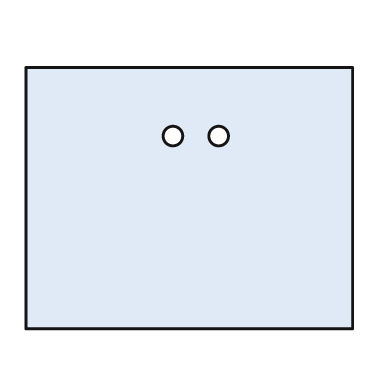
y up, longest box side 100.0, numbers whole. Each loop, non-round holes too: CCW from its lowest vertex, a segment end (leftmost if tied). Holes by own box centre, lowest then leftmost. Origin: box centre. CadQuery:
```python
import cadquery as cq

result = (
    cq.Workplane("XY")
    .moveTo(-50.0, -40.0)
    .lineTo(50.0, -40.0)
    .lineTo(50.0, 40.0)
    .lineTo(-50.0, 40.0)
    .close()
    .moveTo(-5.0, 19.0)
    .circle(3.0)
    .moveTo(9.0, 19.0)
    .circle(3.0)
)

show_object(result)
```